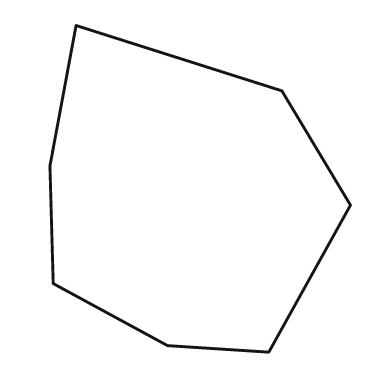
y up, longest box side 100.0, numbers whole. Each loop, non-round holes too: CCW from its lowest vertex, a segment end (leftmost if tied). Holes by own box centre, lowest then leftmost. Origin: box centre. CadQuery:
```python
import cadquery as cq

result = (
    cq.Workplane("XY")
    .moveTo(21.0, -50.0)
    .lineTo(46.0, -5.0)
    .lineTo(25.0, 30.0)
    .lineTo(-38.0, 50.0)
    .lineTo(-46.0, 7.0)
    .lineTo(-45.0, -29.0)
    .lineTo(-10.0, -48.0)
    .close()
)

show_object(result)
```